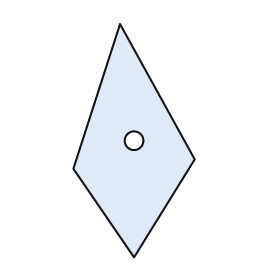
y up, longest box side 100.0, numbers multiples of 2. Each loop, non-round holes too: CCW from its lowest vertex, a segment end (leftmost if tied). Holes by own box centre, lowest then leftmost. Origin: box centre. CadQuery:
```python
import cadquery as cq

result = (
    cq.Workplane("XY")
    .moveTo(0.0, -50.0)
    .lineTo(26.0, -8.0)
    .lineTo(-6.0, 50.0)
    .lineTo(-26.0, -12.0)
    .close()
    .moveTo(0.0, 0.0)
    .circle(4.0)
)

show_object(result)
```